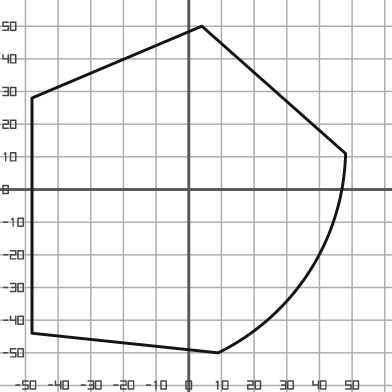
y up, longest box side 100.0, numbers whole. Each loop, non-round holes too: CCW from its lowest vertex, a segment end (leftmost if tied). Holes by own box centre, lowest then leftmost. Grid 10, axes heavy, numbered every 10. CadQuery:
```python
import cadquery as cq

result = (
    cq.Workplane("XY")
    .moveTo(9.0, -50.0)
    .threePointArc((37.0, -25.0), (48.0, 11.0))
    .lineTo(4.0, 50.0)
    .lineTo(-48.0, 28.0)
    .lineTo(-48.0, -44.0)
    .close()
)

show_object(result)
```